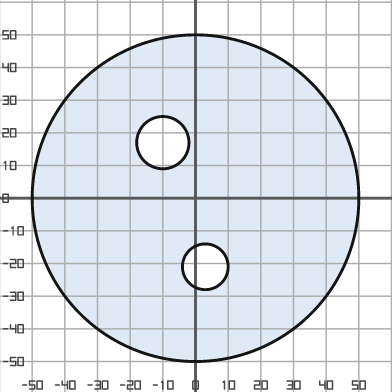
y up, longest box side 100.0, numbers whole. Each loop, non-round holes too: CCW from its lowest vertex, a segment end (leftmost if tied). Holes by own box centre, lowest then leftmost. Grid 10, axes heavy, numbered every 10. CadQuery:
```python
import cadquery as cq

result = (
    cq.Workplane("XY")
    .moveTo(0.0, 0.0)
    .circle(50.0)
    .moveTo(3.0, -21.0)
    .circle(7.0)
    .moveTo(-10.0, 17.0)
    .circle(8.0)
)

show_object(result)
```